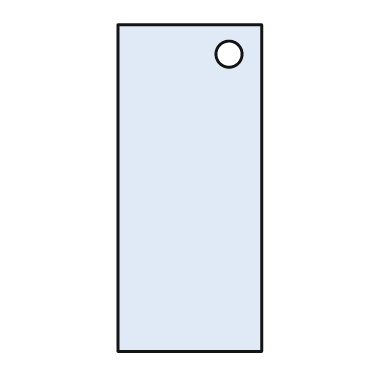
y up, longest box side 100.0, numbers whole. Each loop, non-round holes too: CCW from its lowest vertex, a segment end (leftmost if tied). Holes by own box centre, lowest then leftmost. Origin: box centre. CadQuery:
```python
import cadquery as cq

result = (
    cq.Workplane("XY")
    .moveTo(-22.0, -50.0)
    .lineTo(22.0, -50.0)
    .lineTo(22.0, 50.0)
    .lineTo(-22.0, 50.0)
    .close()
    .moveTo(12.0, 41.0)
    .circle(4.0)
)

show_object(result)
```